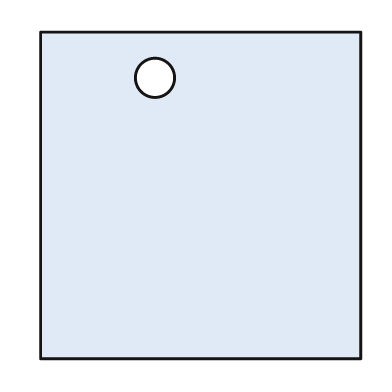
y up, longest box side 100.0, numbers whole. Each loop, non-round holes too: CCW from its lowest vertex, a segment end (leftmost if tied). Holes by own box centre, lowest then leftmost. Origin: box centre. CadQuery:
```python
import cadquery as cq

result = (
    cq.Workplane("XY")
    .moveTo(-49.0, -50.0)
    .lineTo(49.0, -50.0)
    .lineTo(49.0, 50.0)
    .lineTo(-49.0, 50.0)
    .close()
    .moveTo(-14.0, 36.0)
    .circle(6.0)
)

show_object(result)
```